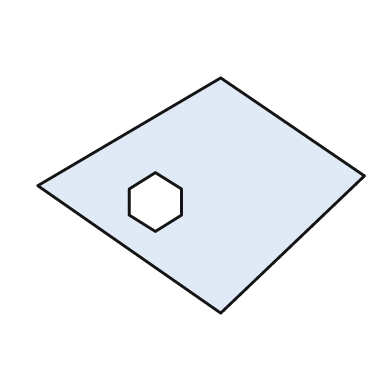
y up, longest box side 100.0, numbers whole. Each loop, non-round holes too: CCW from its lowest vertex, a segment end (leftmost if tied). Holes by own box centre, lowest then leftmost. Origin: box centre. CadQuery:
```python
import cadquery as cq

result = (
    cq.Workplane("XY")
    .moveTo(6.0, -36.0)
    .lineTo(50.0, 6.0)
    .lineTo(6.0, 36.0)
    .lineTo(-50.0, 3.0)
    .close()
    .moveTo(-14.0, -11.0)
    .lineTo(-6.0, -6.0)
    .lineTo(-6.0, 2.0)
    .lineTo(-14.0, 7.0)
    .lineTo(-22.0, 2.0)
    .lineTo(-22.0, -6.0)
    .close()
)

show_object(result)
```